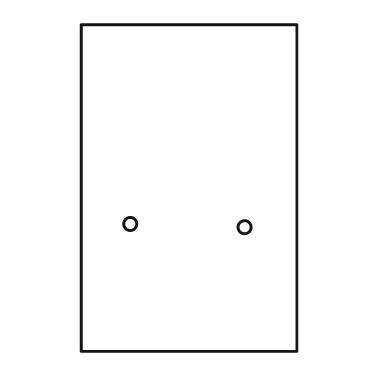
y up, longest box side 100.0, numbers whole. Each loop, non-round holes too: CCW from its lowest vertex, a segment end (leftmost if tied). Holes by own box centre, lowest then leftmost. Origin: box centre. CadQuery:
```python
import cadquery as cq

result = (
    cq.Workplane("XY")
    .moveTo(-33.0, -50.0)
    .lineTo(33.0, -50.0)
    .lineTo(33.0, 50.0)
    .lineTo(-33.0, 50.0)
    .close()
    .moveTo(17.0, -12.0)
    .circle(2.0)
    .moveTo(-18.0, -11.0)
    .circle(2.0)
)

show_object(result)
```